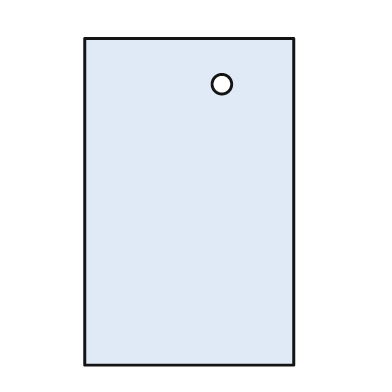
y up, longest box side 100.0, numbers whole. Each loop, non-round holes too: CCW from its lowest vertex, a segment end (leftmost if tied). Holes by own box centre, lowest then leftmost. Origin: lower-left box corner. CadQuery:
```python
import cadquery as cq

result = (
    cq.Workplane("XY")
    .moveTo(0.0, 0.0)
    .lineTo(64.0, 0.0)
    .lineTo(64.0, 100.0)
    .lineTo(0.0, 100.0)
    .close()
    .moveTo(42.0, 86.0)
    .circle(3.0)
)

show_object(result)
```